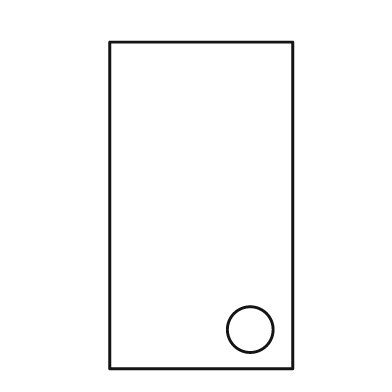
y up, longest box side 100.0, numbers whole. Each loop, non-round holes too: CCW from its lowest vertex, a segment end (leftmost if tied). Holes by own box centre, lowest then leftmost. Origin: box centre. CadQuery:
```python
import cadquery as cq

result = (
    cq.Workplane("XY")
    .moveTo(-28.0, -50.0)
    .lineTo(28.0, -50.0)
    .lineTo(28.0, 50.0)
    .lineTo(-28.0, 50.0)
    .close()
    .moveTo(15.0, -38.0)
    .circle(7.0)
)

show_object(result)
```